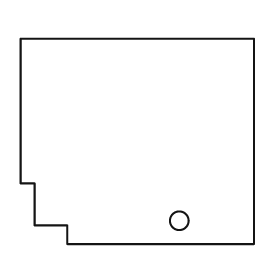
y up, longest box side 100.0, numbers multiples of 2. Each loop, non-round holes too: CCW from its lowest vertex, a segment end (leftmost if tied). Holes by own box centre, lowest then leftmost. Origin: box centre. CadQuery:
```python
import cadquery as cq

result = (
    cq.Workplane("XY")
    .moveTo(-30.0, -44.0)
    .lineTo(50.0, -44.0)
    .lineTo(50.0, 44.0)
    .lineTo(-50.0, 44.0)
    .lineTo(-50.0, -18.0)
    .lineTo(-44.0, -18.0)
    .lineTo(-44.0, -36.0)
    .lineTo(-30.0, -36.0)
    .close()
    .moveTo(18.0, -34.0)
    .circle(4.0)
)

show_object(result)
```